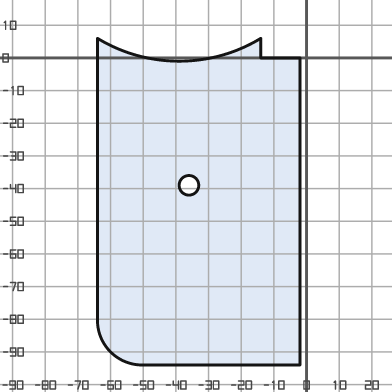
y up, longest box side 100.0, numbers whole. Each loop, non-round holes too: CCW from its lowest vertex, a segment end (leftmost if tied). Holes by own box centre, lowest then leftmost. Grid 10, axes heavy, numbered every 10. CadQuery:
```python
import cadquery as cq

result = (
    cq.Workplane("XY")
    .moveTo(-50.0, -94.0)
    .lineTo(-2.0, -94.0)
    .lineTo(-2.0, 0.0)
    .lineTo(-14.0, 0.0)
    .lineTo(-14.0, 6.0)
    .threePointArc((-39.0, -1.0), (-64.0, 6.0))
    .lineTo(-64.0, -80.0)
    .threePointArc((-60.0, -90.0), (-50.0, -94.0))
    .close()
    .moveTo(-36.0, -39.0)
    .circle(3.0)
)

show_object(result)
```